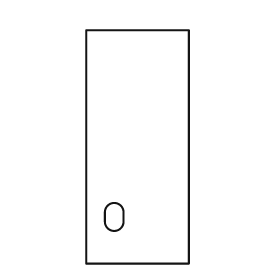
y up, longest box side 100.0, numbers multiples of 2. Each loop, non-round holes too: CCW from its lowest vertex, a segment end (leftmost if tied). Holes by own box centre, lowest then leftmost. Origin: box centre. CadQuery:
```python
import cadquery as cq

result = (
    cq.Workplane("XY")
    .moveTo(-22.0, -50.0)
    .lineTo(22.0, -50.0)
    .lineTo(22.0, 50.0)
    .lineTo(-22.0, 50.0)
    .close()
    .moveTo(-14.0, -32.0)
    .threePointArc((-10.0, -36.0), (-6.0, -32.0))
    .lineTo(-6.0, -28.0)
    .threePointArc((-10.0, -24.0), (-14.0, -28.0))
    .close()
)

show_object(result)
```